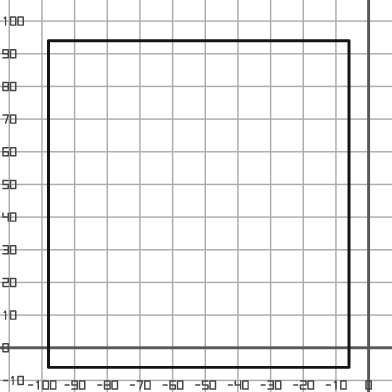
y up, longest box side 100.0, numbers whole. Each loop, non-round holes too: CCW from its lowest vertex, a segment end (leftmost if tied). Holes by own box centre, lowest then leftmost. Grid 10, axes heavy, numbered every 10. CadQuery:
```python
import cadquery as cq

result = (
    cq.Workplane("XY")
    .moveTo(-98.0, -6.0)
    .lineTo(-6.0, -6.0)
    .lineTo(-6.0, 94.0)
    .lineTo(-98.0, 94.0)
    .close()
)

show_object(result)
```